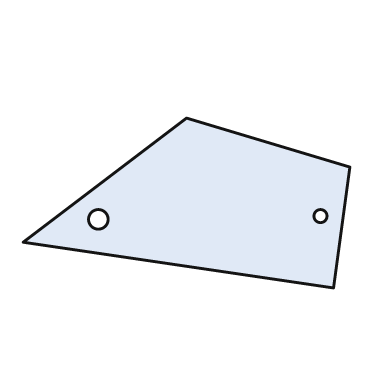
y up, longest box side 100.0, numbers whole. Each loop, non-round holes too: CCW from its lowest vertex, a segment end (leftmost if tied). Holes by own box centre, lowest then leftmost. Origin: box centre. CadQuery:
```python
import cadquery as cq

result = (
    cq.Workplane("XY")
    .moveTo(45.0, -26.0)
    .lineTo(50.0, 11.0)
    .lineTo(0.0, 26.0)
    .lineTo(-50.0, -12.0)
    .close()
    .moveTo(-27.0, -5.0)
    .circle(3.0)
    .moveTo(41.0, -4.0)
    .circle(2.0)
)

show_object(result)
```